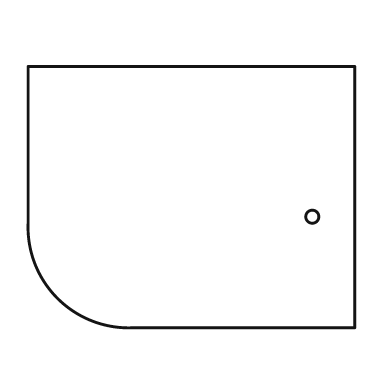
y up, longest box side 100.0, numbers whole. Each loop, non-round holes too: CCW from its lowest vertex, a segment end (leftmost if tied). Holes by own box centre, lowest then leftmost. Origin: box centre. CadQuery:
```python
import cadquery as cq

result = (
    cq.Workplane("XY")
    .moveTo(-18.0, -40.0)
    .lineTo(50.0, -40.0)
    .lineTo(50.0, 40.0)
    .lineTo(-50.0, 40.0)
    .lineTo(-50.0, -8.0)
    .threePointArc((-41.0, -31.0), (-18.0, -40.0))
    .close()
    .moveTo(37.0, -6.0)
    .circle(2.0)
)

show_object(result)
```